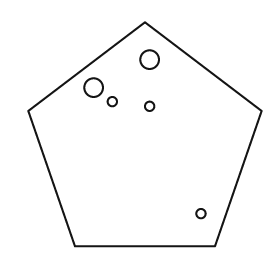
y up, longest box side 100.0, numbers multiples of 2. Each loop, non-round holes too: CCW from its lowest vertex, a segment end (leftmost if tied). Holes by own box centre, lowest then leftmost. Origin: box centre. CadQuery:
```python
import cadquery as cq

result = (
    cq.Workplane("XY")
    .moveTo(-30.0, -48.0)
    .lineTo(30.0, -48.0)
    .lineTo(50.0, 10.0)
    .lineTo(0.0, 48.0)
    .lineTo(-50.0, 10.0)
    .close()
    .moveTo(24.0, -34.0)
    .circle(2.0)
    .moveTo(2.0, 12.0)
    .circle(2.0)
    .moveTo(-14.0, 14.0)
    .circle(2.0)
    .moveTo(-22.0, 20.0)
    .circle(4.0)
    .moveTo(2.0, 32.0)
    .circle(4.0)
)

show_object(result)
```